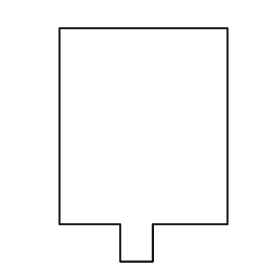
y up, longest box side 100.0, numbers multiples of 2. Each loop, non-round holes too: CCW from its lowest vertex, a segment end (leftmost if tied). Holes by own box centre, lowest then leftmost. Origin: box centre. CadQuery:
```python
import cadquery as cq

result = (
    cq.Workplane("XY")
    .moveTo(-10.0, -50.0)
    .lineTo(4.0, -50.0)
    .lineTo(4.0, -34.0)
    .lineTo(36.0, -34.0)
    .lineTo(36.0, 50.0)
    .lineTo(-36.0, 50.0)
    .lineTo(-36.0, -34.0)
    .lineTo(-10.0, -34.0)
    .close()
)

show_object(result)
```